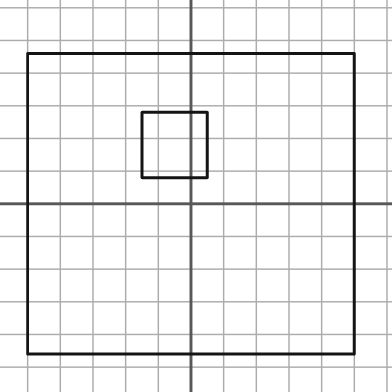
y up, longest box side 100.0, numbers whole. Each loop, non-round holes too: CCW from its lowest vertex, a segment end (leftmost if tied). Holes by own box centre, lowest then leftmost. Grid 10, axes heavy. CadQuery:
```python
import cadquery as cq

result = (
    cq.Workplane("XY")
    .moveTo(-50.0, -46.0)
    .lineTo(50.0, -46.0)
    .lineTo(50.0, 46.0)
    .lineTo(-50.0, 46.0)
    .close()
    .moveTo(-15.0, 8.0)
    .lineTo(5.0, 8.0)
    .lineTo(5.0, 28.0)
    .lineTo(-15.0, 28.0)
    .close()
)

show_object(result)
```